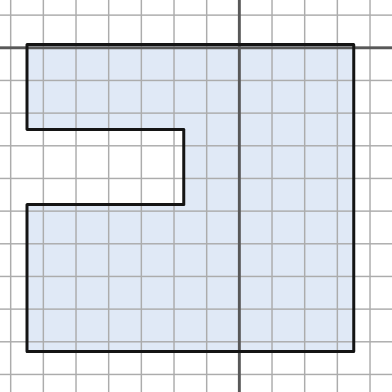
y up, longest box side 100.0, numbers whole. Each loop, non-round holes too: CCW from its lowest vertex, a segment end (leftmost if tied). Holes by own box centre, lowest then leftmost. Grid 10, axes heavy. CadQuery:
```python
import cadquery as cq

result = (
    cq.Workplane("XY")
    .moveTo(-65.0, -93.0)
    .lineTo(35.0, -93.0)
    .lineTo(35.0, 1.0)
    .lineTo(-65.0, 1.0)
    .lineTo(-65.0, -25.0)
    .lineTo(-17.0, -25.0)
    .lineTo(-17.0, -48.0)
    .lineTo(-65.0, -48.0)
    .close()
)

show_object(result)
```